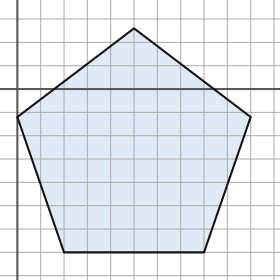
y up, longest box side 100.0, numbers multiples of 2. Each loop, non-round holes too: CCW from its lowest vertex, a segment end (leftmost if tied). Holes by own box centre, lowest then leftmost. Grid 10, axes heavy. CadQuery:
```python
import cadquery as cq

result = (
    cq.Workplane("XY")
    .moveTo(20.0, -70.0)
    .lineTo(80.0, -70.0)
    .lineTo(100.0, -12.0)
    .lineTo(50.0, 26.0)
    .lineTo(0.0, -12.0)
    .close()
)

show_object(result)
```